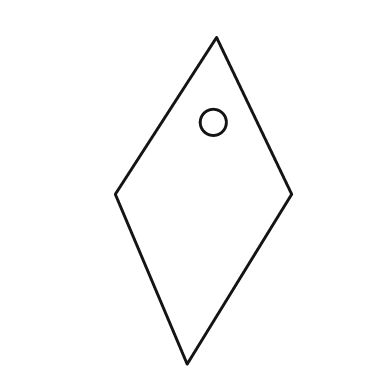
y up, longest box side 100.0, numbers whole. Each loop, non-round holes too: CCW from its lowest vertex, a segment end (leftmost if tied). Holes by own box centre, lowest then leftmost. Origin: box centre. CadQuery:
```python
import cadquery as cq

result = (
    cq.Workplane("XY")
    .moveTo(-5.0, -50.0)
    .lineTo(27.0, 2.0)
    .lineTo(4.0, 50.0)
    .lineTo(-27.0, 2.0)
    .close()
    .moveTo(3.0, 24.0)
    .circle(4.0)
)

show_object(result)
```